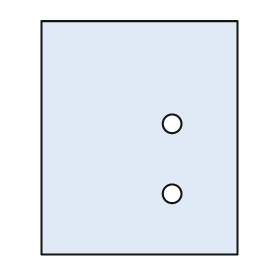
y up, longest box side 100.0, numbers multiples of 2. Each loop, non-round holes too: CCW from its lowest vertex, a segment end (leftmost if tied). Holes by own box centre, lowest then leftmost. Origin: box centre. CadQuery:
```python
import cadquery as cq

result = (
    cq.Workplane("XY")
    .moveTo(-42.0, -50.0)
    .lineTo(42.0, -50.0)
    .lineTo(42.0, 50.0)
    .lineTo(-42.0, 50.0)
    .close()
    .moveTo(14.0, -24.0)
    .circle(4.0)
    .moveTo(14.0, 6.0)
    .circle(4.0)
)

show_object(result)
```